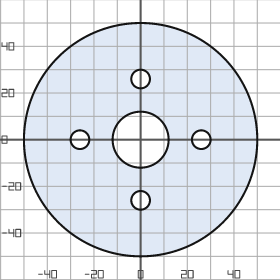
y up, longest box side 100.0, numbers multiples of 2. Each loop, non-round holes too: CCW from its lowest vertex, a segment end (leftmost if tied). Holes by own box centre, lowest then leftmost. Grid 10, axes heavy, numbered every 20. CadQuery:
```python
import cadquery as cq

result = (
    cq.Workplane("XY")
    .moveTo(0.0, 0.0)
    .circle(50.0)
    .moveTo(0.0, -26.0)
    .circle(4.0)
    .moveTo(-26.0, 0.0)
    .circle(4.0)
    .moveTo(0.0, 0.0)
    .circle(12.0)
    .moveTo(26.0, 0.0)
    .circle(4.0)
    .moveTo(0.0, 26.0)
    .circle(4.0)
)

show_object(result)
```